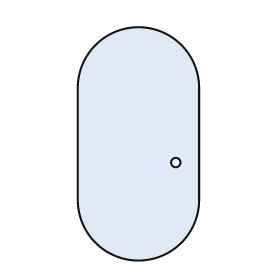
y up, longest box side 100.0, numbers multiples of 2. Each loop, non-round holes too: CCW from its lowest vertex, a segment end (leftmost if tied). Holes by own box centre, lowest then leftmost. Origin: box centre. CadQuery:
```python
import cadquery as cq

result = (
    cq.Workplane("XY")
    .moveTo(-26.0, -24.0)
    .threePointArc((0.0, -50.0), (26.0, -24.0))
    .lineTo(26.0, 24.0)
    .threePointArc((0.0, 50.0), (-26.0, 24.0))
    .close()
    .moveTo(16.0, -8.0)
    .circle(2.0)
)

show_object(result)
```